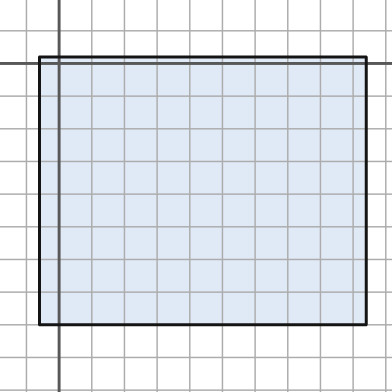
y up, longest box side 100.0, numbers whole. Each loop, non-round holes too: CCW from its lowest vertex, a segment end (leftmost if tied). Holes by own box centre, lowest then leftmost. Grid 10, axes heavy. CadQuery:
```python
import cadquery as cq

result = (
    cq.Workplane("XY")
    .moveTo(-6.0, -80.0)
    .lineTo(94.0, -80.0)
    .lineTo(94.0, 2.0)
    .lineTo(-6.0, 2.0)
    .close()
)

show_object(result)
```